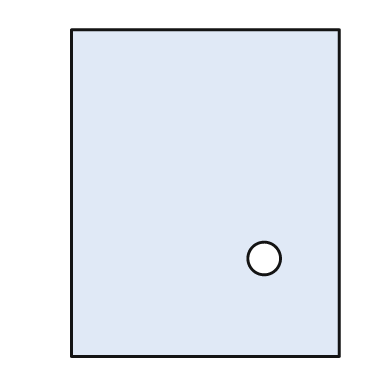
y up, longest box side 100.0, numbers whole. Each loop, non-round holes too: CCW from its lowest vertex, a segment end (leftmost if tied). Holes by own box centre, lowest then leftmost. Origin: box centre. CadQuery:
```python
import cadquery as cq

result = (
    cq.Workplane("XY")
    .moveTo(-41.0, -50.0)
    .lineTo(41.0, -50.0)
    .lineTo(41.0, 50.0)
    .lineTo(-41.0, 50.0)
    .close()
    .moveTo(18.0, -20.0)
    .circle(5.0)
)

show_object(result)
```